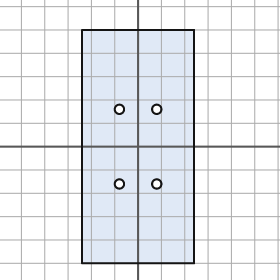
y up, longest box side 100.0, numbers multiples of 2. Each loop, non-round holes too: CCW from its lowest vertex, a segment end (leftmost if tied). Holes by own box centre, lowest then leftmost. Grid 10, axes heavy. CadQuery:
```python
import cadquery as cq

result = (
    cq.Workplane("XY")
    .moveTo(-24.0, -50.0)
    .lineTo(24.0, -50.0)
    .lineTo(24.0, 50.0)
    .lineTo(-24.0, 50.0)
    .close()
    .moveTo(-8.0, -16.0)
    .circle(2.0)
    .moveTo(8.0, -16.0)
    .circle(2.0)
    .moveTo(-8.0, 16.0)
    .circle(2.0)
    .moveTo(8.0, 16.0)
    .circle(2.0)
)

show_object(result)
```